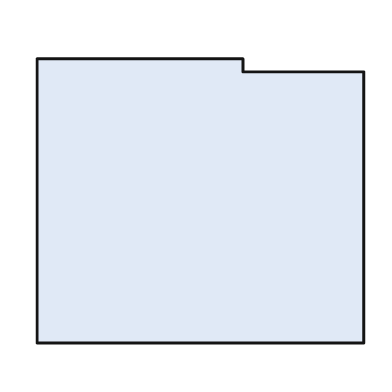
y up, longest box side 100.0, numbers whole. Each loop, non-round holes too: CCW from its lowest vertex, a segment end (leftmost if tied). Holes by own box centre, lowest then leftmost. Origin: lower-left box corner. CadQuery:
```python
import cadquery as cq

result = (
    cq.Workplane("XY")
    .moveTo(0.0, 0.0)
    .lineTo(100.0, 0.0)
    .lineTo(100.0, 83.0)
    .lineTo(63.0, 83.0)
    .lineTo(63.0, 87.0)
    .lineTo(0.0, 87.0)
    .close()
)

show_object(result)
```